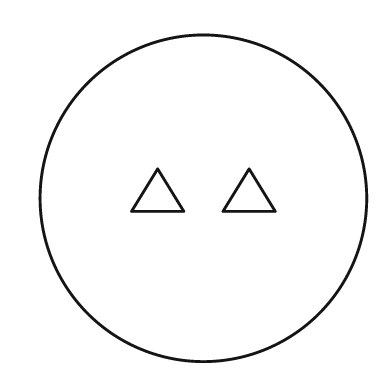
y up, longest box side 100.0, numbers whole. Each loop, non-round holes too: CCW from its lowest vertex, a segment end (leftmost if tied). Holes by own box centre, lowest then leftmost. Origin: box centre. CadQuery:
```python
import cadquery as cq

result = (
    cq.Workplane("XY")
    .moveTo(0.0, 0.0)
    .circle(50.0)
    .moveTo(-22.0, -4.0)
    .lineTo(-6.0, -4.0)
    .lineTo(-14.0, 9.0)
    .close()
    .moveTo(6.0, -4.0)
    .lineTo(22.0, -4.0)
    .lineTo(14.0, 9.0)
    .close()
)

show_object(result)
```